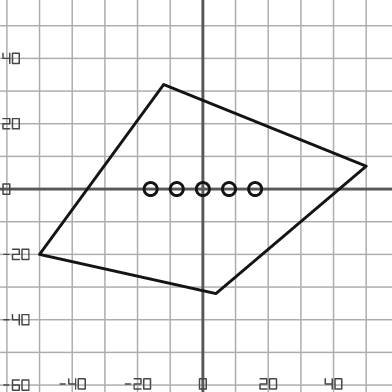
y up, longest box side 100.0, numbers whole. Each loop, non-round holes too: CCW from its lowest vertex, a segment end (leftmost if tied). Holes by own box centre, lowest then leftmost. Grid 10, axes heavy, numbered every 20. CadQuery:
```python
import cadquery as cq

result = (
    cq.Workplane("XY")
    .moveTo(4.0, -32.0)
    .lineTo(50.0, 7.0)
    .lineTo(-12.0, 32.0)
    .lineTo(-50.0, -20.0)
    .close()
    .moveTo(-16.0, 0.0)
    .circle(2.0)
    .moveTo(-8.0, 0.0)
    .circle(2.0)
    .moveTo(0.0, 0.0)
    .circle(2.0)
    .moveTo(8.0, 0.0)
    .circle(2.0)
    .moveTo(16.0, 0.0)
    .circle(2.0)
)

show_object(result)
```